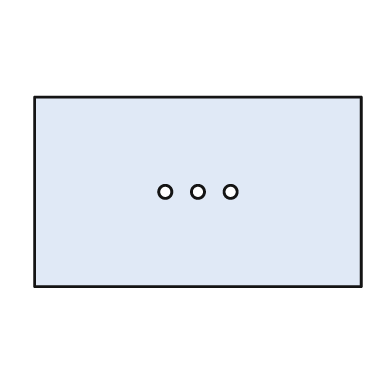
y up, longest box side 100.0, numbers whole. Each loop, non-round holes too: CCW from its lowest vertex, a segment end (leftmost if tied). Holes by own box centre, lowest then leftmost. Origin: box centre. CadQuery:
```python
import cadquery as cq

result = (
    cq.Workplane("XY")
    .moveTo(-50.0, -29.0)
    .lineTo(50.0, -29.0)
    .lineTo(50.0, 29.0)
    .lineTo(-50.0, 29.0)
    .close()
    .moveTo(-10.0, 0.0)
    .circle(2.0)
    .moveTo(0.0, 0.0)
    .circle(2.0)
    .moveTo(10.0, 0.0)
    .circle(2.0)
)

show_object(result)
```